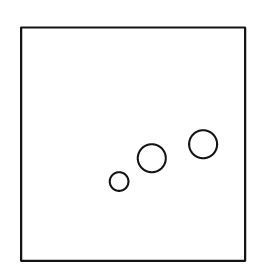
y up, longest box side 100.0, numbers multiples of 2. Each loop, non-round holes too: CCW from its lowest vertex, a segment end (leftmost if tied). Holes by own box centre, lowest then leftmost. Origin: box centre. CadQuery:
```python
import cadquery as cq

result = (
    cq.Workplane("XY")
    .moveTo(-48.0, -50.0)
    .lineTo(48.0, -50.0)
    .lineTo(48.0, 50.0)
    .lineTo(-48.0, 50.0)
    .close()
    .moveTo(-6.0, -16.0)
    .circle(4.0)
    .moveTo(8.0, -6.0)
    .circle(6.0)
    .moveTo(30.0, 0.0)
    .circle(6.0)
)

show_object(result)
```